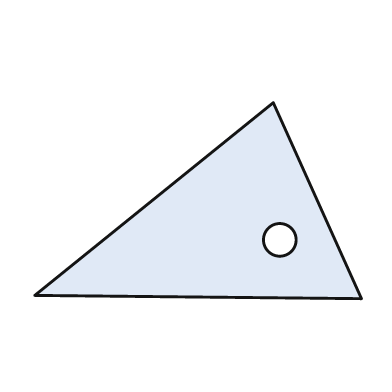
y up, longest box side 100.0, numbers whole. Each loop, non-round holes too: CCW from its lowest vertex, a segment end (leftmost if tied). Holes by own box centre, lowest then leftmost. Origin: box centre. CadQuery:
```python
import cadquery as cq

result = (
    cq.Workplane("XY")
    .moveTo(50.0, -30.0)
    .lineTo(23.0, 30.0)
    .lineTo(-50.0, -29.0)
    .close()
    .moveTo(25.0, -12.0)
    .circle(5.0)
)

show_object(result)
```